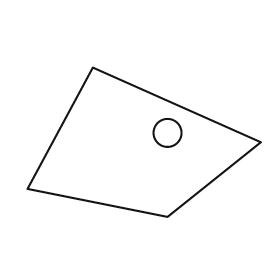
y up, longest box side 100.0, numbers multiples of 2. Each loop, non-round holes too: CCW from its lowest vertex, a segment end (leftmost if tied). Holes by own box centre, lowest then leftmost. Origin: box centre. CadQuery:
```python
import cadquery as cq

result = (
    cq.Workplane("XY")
    .moveTo(10.0, -32.0)
    .lineTo(50.0, 0.0)
    .lineTo(-22.0, 32.0)
    .lineTo(-50.0, -20.0)
    .close()
    .moveTo(10.0, 4.0)
    .circle(6.0)
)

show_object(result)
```